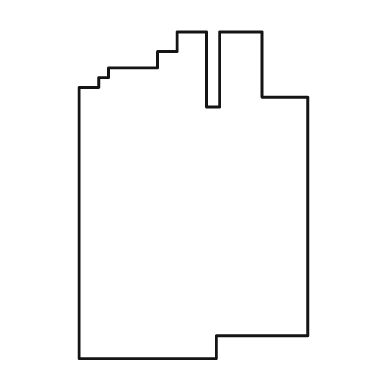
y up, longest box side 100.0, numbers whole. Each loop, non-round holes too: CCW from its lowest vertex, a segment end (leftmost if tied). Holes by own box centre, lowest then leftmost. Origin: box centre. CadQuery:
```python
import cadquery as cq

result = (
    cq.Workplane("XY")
    .moveTo(-35.0, -50.0)
    .lineTo(7.0, -50.0)
    .lineTo(7.0, -43.0)
    .lineTo(35.0, -43.0)
    .lineTo(35.0, 30.0)
    .lineTo(21.0, 30.0)
    .lineTo(21.0, 50.0)
    .lineTo(8.0, 50.0)
    .lineTo(8.0, 27.0)
    .lineTo(4.0, 27.0)
    .lineTo(4.0, 50.0)
    .lineTo(-5.0, 50.0)
    .lineTo(-5.0, 44.0)
    .lineTo(-11.0, 44.0)
    .lineTo(-11.0, 39.0)
    .lineTo(-26.0, 39.0)
    .lineTo(-26.0, 36.0)
    .lineTo(-29.0, 36.0)
    .lineTo(-29.0, 33.0)
    .lineTo(-35.0, 33.0)
    .close()
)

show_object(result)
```